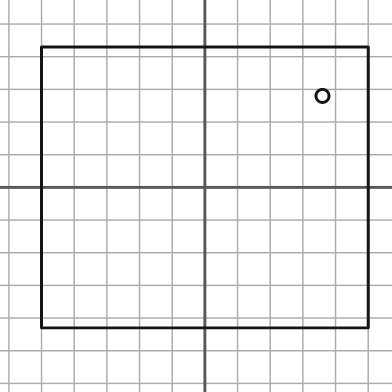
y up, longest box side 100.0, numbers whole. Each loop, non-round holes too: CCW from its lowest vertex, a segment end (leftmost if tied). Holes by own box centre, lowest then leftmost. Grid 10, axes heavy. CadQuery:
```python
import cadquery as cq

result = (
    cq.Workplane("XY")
    .moveTo(-50.0, -43.0)
    .lineTo(50.0, -43.0)
    .lineTo(50.0, 43.0)
    .lineTo(-50.0, 43.0)
    .close()
    .moveTo(36.0, 28.0)
    .circle(2.0)
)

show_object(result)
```